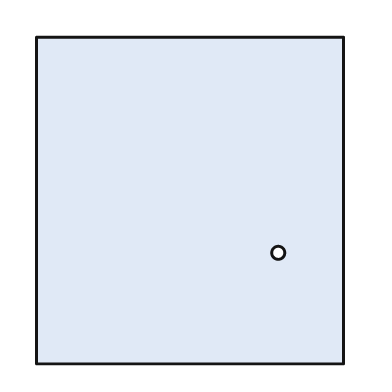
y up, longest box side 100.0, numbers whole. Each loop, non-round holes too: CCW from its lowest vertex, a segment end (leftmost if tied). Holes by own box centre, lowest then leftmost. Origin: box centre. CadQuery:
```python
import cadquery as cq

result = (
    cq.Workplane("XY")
    .moveTo(-47.0, -50.0)
    .lineTo(47.0, -50.0)
    .lineTo(47.0, 50.0)
    .lineTo(-47.0, 50.0)
    .close()
    .moveTo(27.0, -16.0)
    .circle(2.0)
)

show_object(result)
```